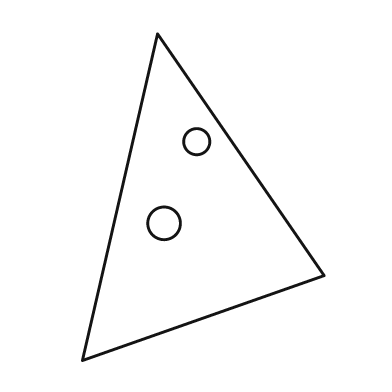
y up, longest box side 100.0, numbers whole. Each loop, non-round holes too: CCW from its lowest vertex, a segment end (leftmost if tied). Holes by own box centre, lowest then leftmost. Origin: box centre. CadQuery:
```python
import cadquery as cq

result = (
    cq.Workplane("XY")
    .moveTo(-37.0, -50.0)
    .lineTo(37.0, -24.0)
    .lineTo(-14.0, 50.0)
    .close()
    .moveTo(-12.0, -8.0)
    .circle(5.0)
    .moveTo(-2.0, 17.0)
    .circle(4.0)
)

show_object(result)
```